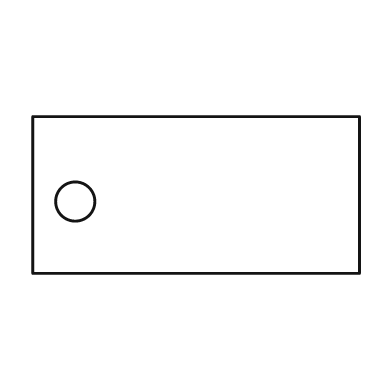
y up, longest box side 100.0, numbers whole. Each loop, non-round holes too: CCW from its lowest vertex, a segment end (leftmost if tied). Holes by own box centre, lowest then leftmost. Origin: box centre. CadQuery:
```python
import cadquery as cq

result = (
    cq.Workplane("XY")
    .moveTo(-50.0, -24.0)
    .lineTo(50.0, -24.0)
    .lineTo(50.0, 24.0)
    .lineTo(-50.0, 24.0)
    .close()
    .moveTo(-37.0, -2.0)
    .circle(6.0)
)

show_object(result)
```